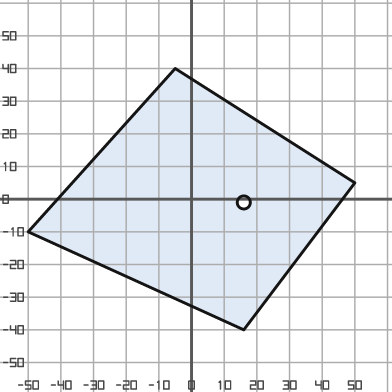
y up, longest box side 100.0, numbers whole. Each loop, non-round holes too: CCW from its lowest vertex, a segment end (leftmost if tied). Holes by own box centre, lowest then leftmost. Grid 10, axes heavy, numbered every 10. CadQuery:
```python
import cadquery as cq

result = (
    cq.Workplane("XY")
    .moveTo(16.0, -40.0)
    .lineTo(50.0, 5.0)
    .lineTo(-5.0, 40.0)
    .lineTo(-50.0, -10.0)
    .close()
    .moveTo(16.0, -1.0)
    .circle(2.0)
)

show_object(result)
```